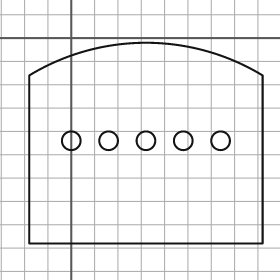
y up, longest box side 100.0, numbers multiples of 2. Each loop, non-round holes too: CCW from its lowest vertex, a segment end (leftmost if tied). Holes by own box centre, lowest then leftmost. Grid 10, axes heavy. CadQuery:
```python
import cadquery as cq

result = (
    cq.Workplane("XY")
    .moveTo(-18.0, -88.0)
    .lineTo(82.0, -88.0)
    .lineTo(82.0, -16.0)
    .threePointArc((32.0, -2.0), (-18.0, -16.0))
    .close()
    .moveTo(0.0, -44.0)
    .circle(4.0)
    .moveTo(16.0, -44.0)
    .circle(4.0)
    .moveTo(32.0, -44.0)
    .circle(4.0)
    .moveTo(48.0, -44.0)
    .circle(4.0)
    .moveTo(64.0, -44.0)
    .circle(4.0)
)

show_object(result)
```